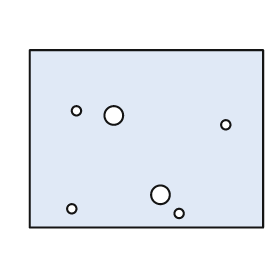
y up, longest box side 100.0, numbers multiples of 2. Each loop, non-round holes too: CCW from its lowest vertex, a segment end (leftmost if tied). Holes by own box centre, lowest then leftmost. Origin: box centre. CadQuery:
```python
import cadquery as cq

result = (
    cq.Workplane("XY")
    .moveTo(-50.0, -38.0)
    .lineTo(50.0, -38.0)
    .lineTo(50.0, 38.0)
    .lineTo(-50.0, 38.0)
    .close()
    .moveTo(14.0, -32.0)
    .circle(2.0)
    .moveTo(-32.0, -30.0)
    .circle(2.0)
    .moveTo(6.0, -24.0)
    .circle(4.0)
    .moveTo(34.0, 6.0)
    .circle(2.0)
    .moveTo(-14.0, 10.0)
    .circle(4.0)
    .moveTo(-30.0, 12.0)
    .circle(2.0)
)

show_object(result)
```